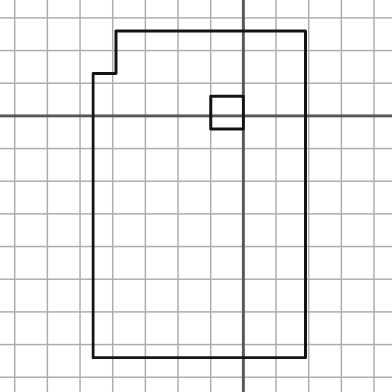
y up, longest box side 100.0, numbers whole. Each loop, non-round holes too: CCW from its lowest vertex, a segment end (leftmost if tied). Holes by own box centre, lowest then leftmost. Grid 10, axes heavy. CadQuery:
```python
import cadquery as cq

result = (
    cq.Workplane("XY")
    .moveTo(-46.0, -74.0)
    .lineTo(19.0, -74.0)
    .lineTo(19.0, 26.0)
    .lineTo(-39.0, 26.0)
    .lineTo(-39.0, 13.0)
    .lineTo(-46.0, 13.0)
    .close()
    .moveTo(-10.0, -4.0)
    .lineTo(0.0, -4.0)
    .lineTo(0.0, 6.0)
    .lineTo(-10.0, 6.0)
    .close()
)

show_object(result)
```